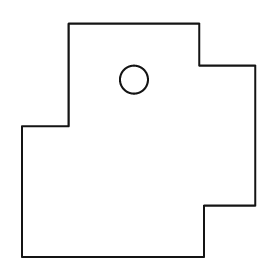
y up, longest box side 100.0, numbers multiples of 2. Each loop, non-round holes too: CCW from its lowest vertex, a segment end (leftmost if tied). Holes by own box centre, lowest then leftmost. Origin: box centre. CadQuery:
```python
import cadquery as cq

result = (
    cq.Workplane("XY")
    .moveTo(-50.0, -50.0)
    .lineTo(28.0, -50.0)
    .lineTo(28.0, -28.0)
    .lineTo(50.0, -28.0)
    .lineTo(50.0, 32.0)
    .lineTo(26.0, 32.0)
    .lineTo(26.0, 50.0)
    .lineTo(-30.0, 50.0)
    .lineTo(-30.0, 6.0)
    .lineTo(-50.0, 6.0)
    .close()
    .moveTo(-2.0, 26.0)
    .circle(6.0)
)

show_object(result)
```